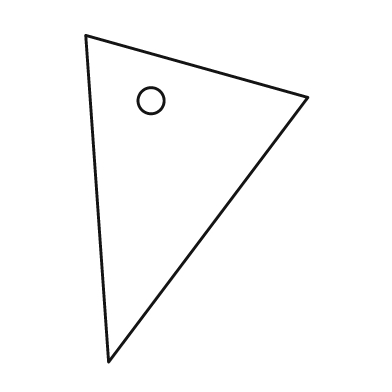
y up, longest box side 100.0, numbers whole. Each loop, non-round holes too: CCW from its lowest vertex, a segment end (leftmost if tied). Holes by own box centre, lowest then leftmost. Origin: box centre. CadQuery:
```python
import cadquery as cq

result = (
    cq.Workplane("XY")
    .moveTo(-27.0, -50.0)
    .lineTo(34.0, 31.0)
    .lineTo(-34.0, 50.0)
    .close()
    .moveTo(-14.0, 30.0)
    .circle(4.0)
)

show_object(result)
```